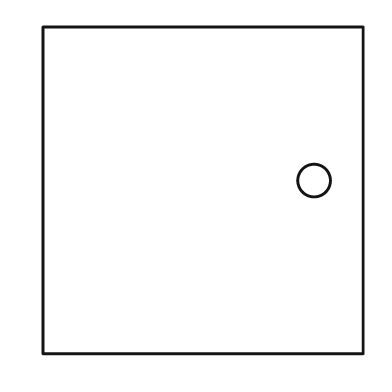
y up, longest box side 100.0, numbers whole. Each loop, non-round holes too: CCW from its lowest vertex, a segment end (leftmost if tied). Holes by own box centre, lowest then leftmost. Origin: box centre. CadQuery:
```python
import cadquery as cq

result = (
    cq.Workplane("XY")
    .moveTo(-49.0, -50.0)
    .lineTo(49.0, -50.0)
    .lineTo(49.0, 50.0)
    .lineTo(-49.0, 50.0)
    .close()
    .moveTo(34.0, 3.0)
    .circle(5.0)
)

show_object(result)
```